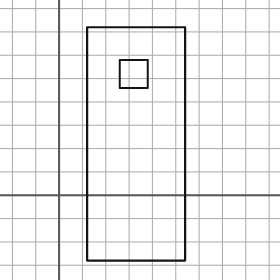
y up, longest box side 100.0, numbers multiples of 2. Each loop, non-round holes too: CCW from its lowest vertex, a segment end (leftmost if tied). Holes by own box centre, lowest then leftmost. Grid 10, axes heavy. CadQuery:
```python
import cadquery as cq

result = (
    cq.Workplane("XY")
    .moveTo(12.0, -28.0)
    .lineTo(54.0, -28.0)
    .lineTo(54.0, 72.0)
    .lineTo(12.0, 72.0)
    .close()
    .moveTo(26.0, 46.0)
    .lineTo(38.0, 46.0)
    .lineTo(38.0, 58.0)
    .lineTo(26.0, 58.0)
    .close()
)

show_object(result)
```